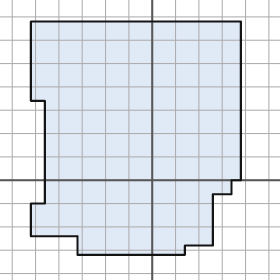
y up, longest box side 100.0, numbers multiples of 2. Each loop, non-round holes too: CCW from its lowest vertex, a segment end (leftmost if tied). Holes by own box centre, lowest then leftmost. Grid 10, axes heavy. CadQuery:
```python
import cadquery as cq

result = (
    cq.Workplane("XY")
    .moveTo(-32.0, -32.0)
    .lineTo(14.0, -32.0)
    .lineTo(14.0, -28.0)
    .lineTo(26.0, -28.0)
    .lineTo(26.0, -6.0)
    .lineTo(34.0, -6.0)
    .lineTo(34.0, 0.0)
    .lineTo(38.0, 0.0)
    .lineTo(38.0, 68.0)
    .lineTo(-52.0, 68.0)
    .lineTo(-52.0, 34.0)
    .lineTo(-46.0, 34.0)
    .lineTo(-46.0, -10.0)
    .lineTo(-52.0, -10.0)
    .lineTo(-52.0, -24.0)
    .lineTo(-32.0, -24.0)
    .close()
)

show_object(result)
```